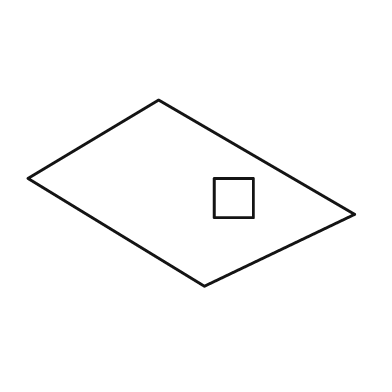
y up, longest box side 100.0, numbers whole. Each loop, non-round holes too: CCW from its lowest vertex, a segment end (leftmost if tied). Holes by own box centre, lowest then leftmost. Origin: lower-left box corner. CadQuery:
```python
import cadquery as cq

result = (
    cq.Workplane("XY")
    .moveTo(54.0, 0.0)
    .lineTo(100.0, 22.0)
    .lineTo(40.0, 57.0)
    .lineTo(0.0, 33.0)
    .close()
    .moveTo(57.0, 21.0)
    .lineTo(69.0, 21.0)
    .lineTo(69.0, 33.0)
    .lineTo(57.0, 33.0)
    .close()
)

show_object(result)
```